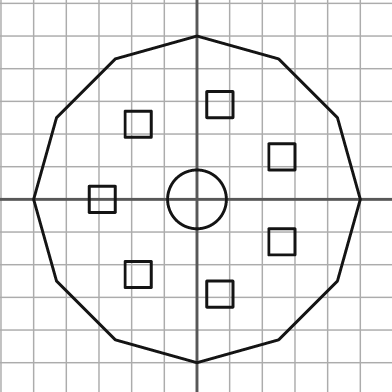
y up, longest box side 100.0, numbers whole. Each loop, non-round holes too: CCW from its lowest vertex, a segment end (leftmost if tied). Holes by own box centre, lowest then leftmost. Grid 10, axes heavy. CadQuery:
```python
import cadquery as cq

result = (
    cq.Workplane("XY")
    .moveTo(0.0, -50.0)
    .lineTo(25.0, -43.0)
    .lineTo(43.0, -25.0)
    .lineTo(50.0, 0.0)
    .lineTo(43.0, 25.0)
    .lineTo(25.0, 43.0)
    .lineTo(0.0, 50.0)
    .lineTo(-25.0, 43.0)
    .lineTo(-43.0, 25.0)
    .lineTo(-50.0, 0.0)
    .lineTo(-43.0, -25.0)
    .lineTo(-25.0, -43.0)
    .close()
    .moveTo(3.0, -33.0)
    .lineTo(11.0, -33.0)
    .lineTo(11.0, -25.0)
    .lineTo(3.0, -25.0)
    .close()
    .moveTo(-22.0, -27.0)
    .lineTo(-14.0, -27.0)
    .lineTo(-14.0, -19.0)
    .lineTo(-22.0, -19.0)
    .close()
    .moveTo(22.0, -17.0)
    .lineTo(30.0, -17.0)
    .lineTo(30.0, -9.0)
    .lineTo(22.0, -9.0)
    .close()
    .moveTo(-33.0, -4.0)
    .lineTo(-25.0, -4.0)
    .lineTo(-25.0, 4.0)
    .lineTo(-33.0, 4.0)
    .close()
    .moveTo(0.0, 0.0)
    .circle(9.0)
    .moveTo(22.0, 9.0)
    .lineTo(30.0, 9.0)
    .lineTo(30.0, 17.0)
    .lineTo(22.0, 17.0)
    .close()
    .moveTo(-22.0, 19.0)
    .lineTo(-14.0, 19.0)
    .lineTo(-14.0, 27.0)
    .lineTo(-22.0, 27.0)
    .close()
    .moveTo(3.0, 25.0)
    .lineTo(11.0, 25.0)
    .lineTo(11.0, 33.0)
    .lineTo(3.0, 33.0)
    .close()
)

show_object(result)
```